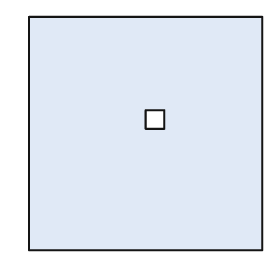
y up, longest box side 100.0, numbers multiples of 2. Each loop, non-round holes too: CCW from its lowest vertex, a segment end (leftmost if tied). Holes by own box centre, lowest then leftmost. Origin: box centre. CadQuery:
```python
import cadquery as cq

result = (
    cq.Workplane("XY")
    .moveTo(-50.0, -50.0)
    .lineTo(50.0, -50.0)
    .lineTo(50.0, 50.0)
    .lineTo(-50.0, 50.0)
    .close()
    .moveTo(0.0, 2.0)
    .lineTo(8.0, 2.0)
    .lineTo(8.0, 10.0)
    .lineTo(0.0, 10.0)
    .close()
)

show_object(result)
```